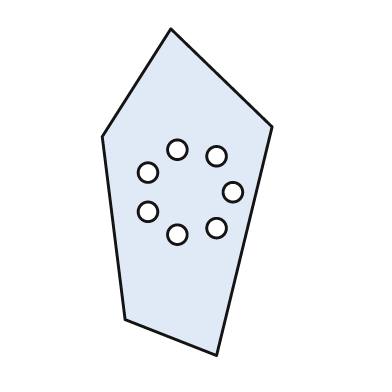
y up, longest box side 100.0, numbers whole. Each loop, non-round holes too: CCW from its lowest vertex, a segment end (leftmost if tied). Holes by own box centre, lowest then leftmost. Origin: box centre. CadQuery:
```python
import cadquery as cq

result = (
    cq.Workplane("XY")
    .moveTo(9.0, -50.0)
    .lineTo(26.0, 20.0)
    .lineTo(-5.0, 50.0)
    .lineTo(-26.0, 17.0)
    .lineTo(-19.0, -39.0)
    .close()
    .moveTo(-3.0, -13.0)
    .circle(3.0)
    .moveTo(9.0, -11.0)
    .circle(3.0)
    .moveTo(-12.0, -6.0)
    .circle(3.0)
    .moveTo(14.0, 0.0)
    .circle(3.0)
    .moveTo(-12.0, 6.0)
    .circle(3.0)
    .moveTo(9.0, 11.0)
    .circle(3.0)
    .moveTo(-3.0, 13.0)
    .circle(3.0)
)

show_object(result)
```